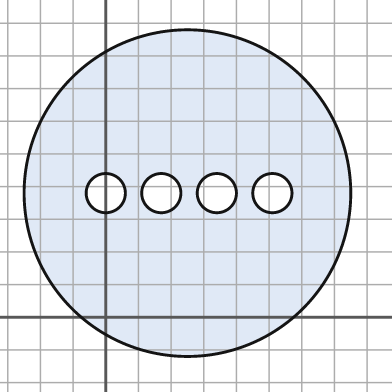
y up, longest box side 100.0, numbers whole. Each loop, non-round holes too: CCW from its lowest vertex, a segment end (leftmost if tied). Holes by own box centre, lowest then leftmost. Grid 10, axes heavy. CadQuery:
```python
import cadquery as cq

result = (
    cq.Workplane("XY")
    .moveTo(25.0, 38.0)
    .circle(50.0)
    .moveTo(0.0, 38.0)
    .circle(6.0)
    .moveTo(17.0, 38.0)
    .circle(6.0)
    .moveTo(34.0, 38.0)
    .circle(6.0)
    .moveTo(51.0, 38.0)
    .circle(6.0)
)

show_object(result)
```